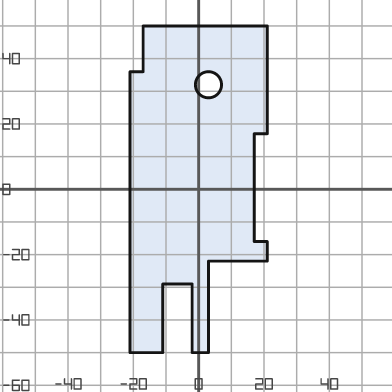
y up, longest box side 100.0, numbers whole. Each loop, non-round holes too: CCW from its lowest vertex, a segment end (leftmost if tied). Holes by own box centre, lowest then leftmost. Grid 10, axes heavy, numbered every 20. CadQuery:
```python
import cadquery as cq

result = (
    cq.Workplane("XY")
    .moveTo(-21.0, -50.0)
    .lineTo(-11.0, -50.0)
    .lineTo(-11.0, -29.0)
    .lineTo(-2.0, -29.0)
    .lineTo(-2.0, -50.0)
    .lineTo(3.0, -50.0)
    .lineTo(3.0, -22.0)
    .lineTo(21.0, -22.0)
    .lineTo(21.0, -16.0)
    .lineTo(17.0, -16.0)
    .lineTo(17.0, 17.0)
    .lineTo(21.0, 17.0)
    .lineTo(21.0, 50.0)
    .lineTo(-17.0, 50.0)
    .lineTo(-17.0, 36.0)
    .lineTo(-21.0, 36.0)
    .close()
    .moveTo(3.0, 32.0)
    .circle(4.0)
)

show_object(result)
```